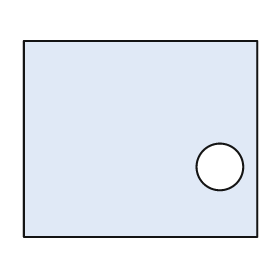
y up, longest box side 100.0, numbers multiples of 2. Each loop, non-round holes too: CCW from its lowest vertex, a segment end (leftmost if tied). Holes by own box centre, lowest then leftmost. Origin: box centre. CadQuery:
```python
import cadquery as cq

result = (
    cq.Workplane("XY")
    .moveTo(-50.0, -42.0)
    .lineTo(50.0, -42.0)
    .lineTo(50.0, 42.0)
    .lineTo(-50.0, 42.0)
    .close()
    .moveTo(34.0, -12.0)
    .circle(10.0)
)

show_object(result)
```